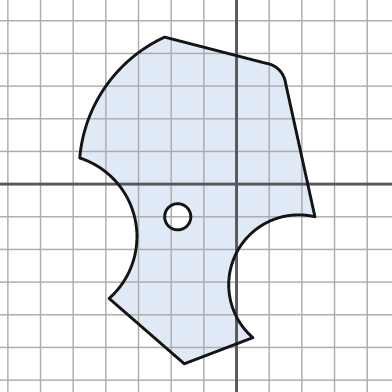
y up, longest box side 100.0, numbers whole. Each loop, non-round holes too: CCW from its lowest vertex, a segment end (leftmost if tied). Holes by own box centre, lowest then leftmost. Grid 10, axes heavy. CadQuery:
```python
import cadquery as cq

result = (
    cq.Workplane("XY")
    .moveTo(-16.0, -55.0)
    .lineTo(5.0, -47.0)
    .threePointArc((0.0, -21.0), (24.0, -10.0))
    .lineTo(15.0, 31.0)
    .threePointArc((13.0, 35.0), (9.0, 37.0))
    .lineTo(-22.0, 45.0)
    .threePointArc((-40.0, 30.0), (-48.0, 8.0))
    .threePointArc((-31.0, -11.0), (-39.0, -35.0))
    .close()
    .moveTo(-18.0, -10.0)
    .circle(4.0)
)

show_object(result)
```